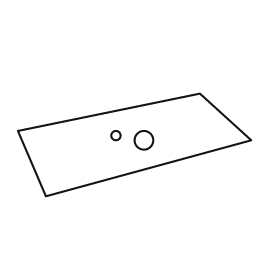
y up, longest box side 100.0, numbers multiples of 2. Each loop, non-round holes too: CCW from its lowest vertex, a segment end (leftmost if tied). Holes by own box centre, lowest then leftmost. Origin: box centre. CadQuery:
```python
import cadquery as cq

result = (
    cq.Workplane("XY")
    .moveTo(-38.0, -22.0)
    .lineTo(50.0, 2.0)
    .lineTo(28.0, 22.0)
    .lineTo(-50.0, 6.0)
    .close()
    .moveTo(4.0, 2.0)
    .circle(4.0)
    .moveTo(-8.0, 4.0)
    .circle(2.0)
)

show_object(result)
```